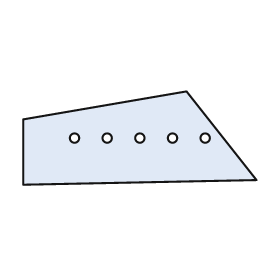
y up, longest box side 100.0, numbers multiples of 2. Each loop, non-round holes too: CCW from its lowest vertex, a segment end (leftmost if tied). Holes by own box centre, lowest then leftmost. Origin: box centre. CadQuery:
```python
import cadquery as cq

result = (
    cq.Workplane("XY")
    .moveTo(-50.0, -20.0)
    .lineTo(50.0, -18.0)
    .lineTo(20.0, 20.0)
    .lineTo(-50.0, 8.0)
    .close()
    .moveTo(-28.0, 0.0)
    .circle(2.0)
    .moveTo(-14.0, 0.0)
    .circle(2.0)
    .moveTo(0.0, 0.0)
    .circle(2.0)
    .moveTo(14.0, 0.0)
    .circle(2.0)
    .moveTo(28.0, 0.0)
    .circle(2.0)
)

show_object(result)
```